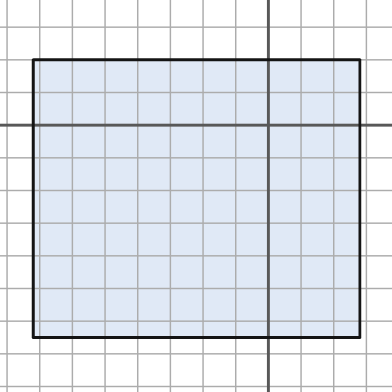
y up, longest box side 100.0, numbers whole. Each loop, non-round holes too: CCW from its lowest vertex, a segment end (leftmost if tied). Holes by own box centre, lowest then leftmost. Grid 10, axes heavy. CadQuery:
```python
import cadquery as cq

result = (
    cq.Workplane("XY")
    .moveTo(-72.0, -65.0)
    .lineTo(28.0, -65.0)
    .lineTo(28.0, 20.0)
    .lineTo(-72.0, 20.0)
    .close()
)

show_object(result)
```